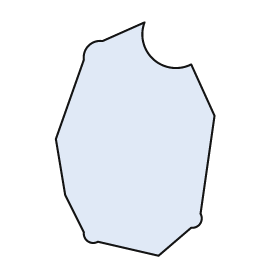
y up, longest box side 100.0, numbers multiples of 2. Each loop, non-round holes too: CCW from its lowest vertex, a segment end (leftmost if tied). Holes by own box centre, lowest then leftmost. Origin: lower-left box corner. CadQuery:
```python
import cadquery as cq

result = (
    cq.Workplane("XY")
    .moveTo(44.0, 0.0)
    .lineTo(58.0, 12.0)
    .threePointArc((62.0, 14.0), (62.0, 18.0))
    .lineTo(68.0, 60.0)
    .lineTo(58.0, 82.0)
    .threePointArc((42.0, 84.0), (38.0, 100.0))
    .lineTo(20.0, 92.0)
    .threePointArc((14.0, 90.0), (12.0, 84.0))
    .lineTo(0.0, 50.0)
    .lineTo(4.0, 26.0)
    .lineTo(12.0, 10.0)
    .threePointArc((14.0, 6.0), (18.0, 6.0))
    .close()
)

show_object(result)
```